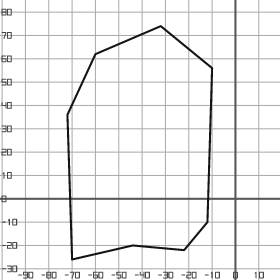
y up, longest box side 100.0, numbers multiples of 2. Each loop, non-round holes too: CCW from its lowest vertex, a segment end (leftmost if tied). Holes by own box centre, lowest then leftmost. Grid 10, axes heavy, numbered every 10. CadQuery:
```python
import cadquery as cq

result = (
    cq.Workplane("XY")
    .moveTo(-70.0, -26.0)
    .lineTo(-44.0, -20.0)
    .lineTo(-22.0, -22.0)
    .lineTo(-12.0, -10.0)
    .lineTo(-10.0, 56.0)
    .lineTo(-32.0, 74.0)
    .lineTo(-60.0, 62.0)
    .lineTo(-72.0, 36.0)
    .close()
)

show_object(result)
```